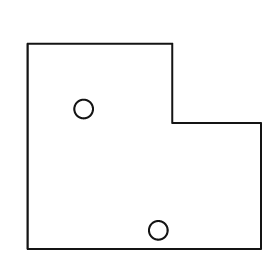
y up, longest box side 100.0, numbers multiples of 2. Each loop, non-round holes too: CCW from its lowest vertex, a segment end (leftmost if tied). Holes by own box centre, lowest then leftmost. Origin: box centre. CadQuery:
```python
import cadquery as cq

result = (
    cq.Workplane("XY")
    .moveTo(-50.0, -44.0)
    .lineTo(50.0, -44.0)
    .lineTo(50.0, 10.0)
    .lineTo(12.0, 10.0)
    .lineTo(12.0, 44.0)
    .lineTo(-50.0, 44.0)
    .close()
    .moveTo(6.0, -36.0)
    .circle(4.0)
    .moveTo(-26.0, 16.0)
    .circle(4.0)
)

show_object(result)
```